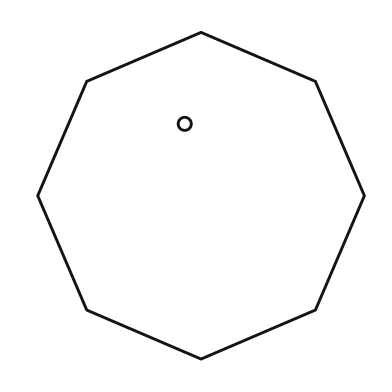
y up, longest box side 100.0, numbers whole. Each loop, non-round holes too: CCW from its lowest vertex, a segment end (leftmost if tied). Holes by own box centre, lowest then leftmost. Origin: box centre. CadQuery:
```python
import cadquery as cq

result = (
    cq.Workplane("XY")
    .moveTo(0.0, -50.0)
    .lineTo(35.0, -35.0)
    .lineTo(50.0, 0.0)
    .lineTo(35.0, 35.0)
    .lineTo(0.0, 50.0)
    .lineTo(-35.0, 35.0)
    .lineTo(-50.0, 0.0)
    .lineTo(-35.0, -35.0)
    .close()
    .moveTo(-5.0, 22.0)
    .circle(2.0)
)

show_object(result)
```